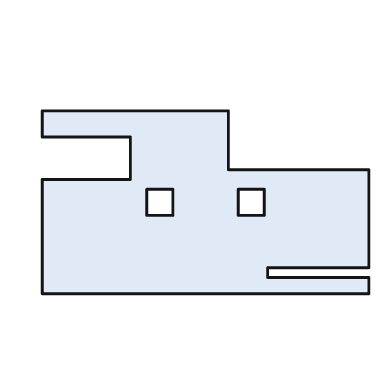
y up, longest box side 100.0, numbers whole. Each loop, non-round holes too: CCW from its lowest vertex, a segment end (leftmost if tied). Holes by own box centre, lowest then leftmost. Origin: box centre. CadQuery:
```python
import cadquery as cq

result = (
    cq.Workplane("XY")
    .moveTo(-50.0, -28.0)
    .lineTo(50.0, -28.0)
    .lineTo(50.0, -23.0)
    .lineTo(19.0, -23.0)
    .lineTo(19.0, -20.0)
    .lineTo(50.0, -20.0)
    .lineTo(50.0, 10.0)
    .lineTo(7.0, 10.0)
    .lineTo(7.0, 28.0)
    .lineTo(-50.0, 28.0)
    .lineTo(-50.0, 20.0)
    .lineTo(-23.0, 20.0)
    .lineTo(-23.0, 7.0)
    .lineTo(-50.0, 7.0)
    .close()
    .moveTo(-18.0, -4.0)
    .lineTo(-10.0, -4.0)
    .lineTo(-10.0, 4.0)
    .lineTo(-18.0, 4.0)
    .close()
    .moveTo(10.0, -4.0)
    .lineTo(18.0, -4.0)
    .lineTo(18.0, 4.0)
    .lineTo(10.0, 4.0)
    .close()
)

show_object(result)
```